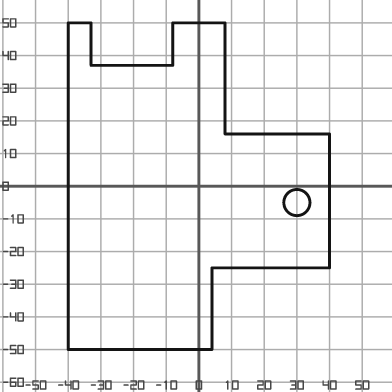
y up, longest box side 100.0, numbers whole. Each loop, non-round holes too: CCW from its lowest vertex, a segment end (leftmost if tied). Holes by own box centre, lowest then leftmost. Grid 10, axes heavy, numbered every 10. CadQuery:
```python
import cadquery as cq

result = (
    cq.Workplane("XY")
    .moveTo(-40.0, -50.0)
    .lineTo(4.0, -50.0)
    .lineTo(4.0, -25.0)
    .lineTo(40.0, -25.0)
    .lineTo(40.0, 16.0)
    .lineTo(8.0, 16.0)
    .lineTo(8.0, 50.0)
    .lineTo(-8.0, 50.0)
    .lineTo(-8.0, 37.0)
    .lineTo(-33.0, 37.0)
    .lineTo(-33.0, 50.0)
    .lineTo(-40.0, 50.0)
    .close()
    .moveTo(30.0, -5.0)
    .circle(4.0)
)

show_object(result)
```